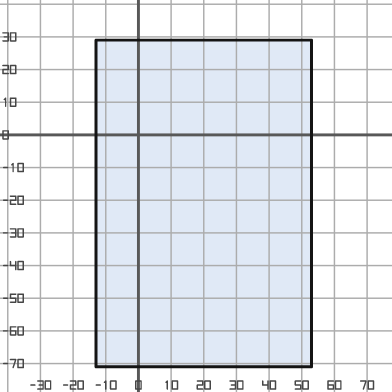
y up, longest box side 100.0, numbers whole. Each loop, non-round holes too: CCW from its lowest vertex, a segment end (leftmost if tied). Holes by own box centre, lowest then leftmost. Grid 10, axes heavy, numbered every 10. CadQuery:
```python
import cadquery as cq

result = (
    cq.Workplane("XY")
    .moveTo(-13.0, -71.0)
    .lineTo(53.0, -71.0)
    .lineTo(53.0, 29.0)
    .lineTo(-13.0, 29.0)
    .close()
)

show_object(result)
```